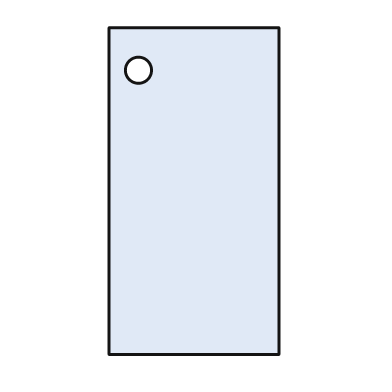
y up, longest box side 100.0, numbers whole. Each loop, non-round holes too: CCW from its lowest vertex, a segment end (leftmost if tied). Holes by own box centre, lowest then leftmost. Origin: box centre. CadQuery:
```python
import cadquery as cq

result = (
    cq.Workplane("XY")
    .moveTo(-26.0, -50.0)
    .lineTo(26.0, -50.0)
    .lineTo(26.0, 50.0)
    .lineTo(-26.0, 50.0)
    .close()
    .moveTo(-17.0, 37.0)
    .circle(4.0)
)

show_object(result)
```